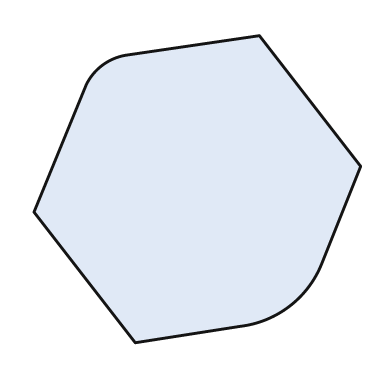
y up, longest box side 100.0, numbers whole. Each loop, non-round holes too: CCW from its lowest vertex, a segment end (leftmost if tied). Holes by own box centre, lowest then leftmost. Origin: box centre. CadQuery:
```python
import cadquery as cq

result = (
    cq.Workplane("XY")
    .moveTo(-19.0, -47.0)
    .lineTo(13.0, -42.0)
    .threePointArc((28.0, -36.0), (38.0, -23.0))
    .lineTo(50.0, 7.0)
    .lineTo(19.0, 47.0)
    .lineTo(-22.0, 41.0)
    .threePointArc((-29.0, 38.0), (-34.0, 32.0))
    .lineTo(-50.0, -7.0)
    .close()
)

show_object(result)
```